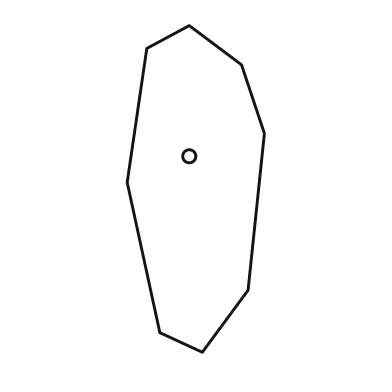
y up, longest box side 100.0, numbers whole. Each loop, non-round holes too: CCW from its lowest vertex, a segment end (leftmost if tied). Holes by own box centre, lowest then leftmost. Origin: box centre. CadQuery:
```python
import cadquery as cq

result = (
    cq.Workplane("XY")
    .moveTo(2.0, -50.0)
    .lineTo(16.0, -31.0)
    .lineTo(21.0, 17.0)
    .lineTo(14.0, 38.0)
    .lineTo(-2.0, 50.0)
    .lineTo(-15.0, 43.0)
    .lineTo(-21.0, 2.0)
    .lineTo(-11.0, -44.0)
    .close()
    .moveTo(-2.0, 10.0)
    .circle(2.0)
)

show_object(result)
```